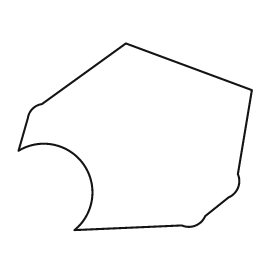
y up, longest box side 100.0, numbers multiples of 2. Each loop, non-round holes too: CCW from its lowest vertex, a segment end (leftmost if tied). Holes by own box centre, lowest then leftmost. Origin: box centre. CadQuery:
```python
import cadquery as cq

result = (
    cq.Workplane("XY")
    .moveTo(-26.0, -40.0)
    .lineTo(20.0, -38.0)
    .threePointArc((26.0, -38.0), (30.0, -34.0))
    .lineTo(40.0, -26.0)
    .threePointArc((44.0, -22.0), (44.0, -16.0))
    .lineTo(50.0, 20.0)
    .lineTo(-4.0, 40.0)
    .lineTo(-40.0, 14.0)
    .threePointArc((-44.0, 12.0), (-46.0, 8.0))
    .lineTo(-50.0, -6.0)
    .threePointArc((-22.0, -12.0), (-26.0, -40.0))
    .close()
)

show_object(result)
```